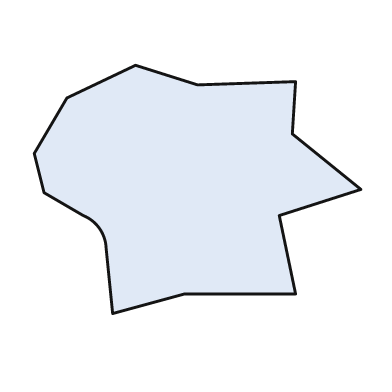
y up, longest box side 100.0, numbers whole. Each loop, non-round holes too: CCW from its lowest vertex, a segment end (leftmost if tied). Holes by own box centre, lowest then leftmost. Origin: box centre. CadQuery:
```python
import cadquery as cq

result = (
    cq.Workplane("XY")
    .moveTo(-26.0, -38.0)
    .lineTo(-4.0, -32.0)
    .lineTo(30.0, -32.0)
    .lineTo(25.0, -8.0)
    .lineTo(50.0, 0.0)
    .lineTo(29.0, 17.0)
    .lineTo(30.0, 33.0)
    .lineTo(0.0, 32.0)
    .lineTo(-19.0, 38.0)
    .lineTo(-40.0, 28.0)
    .lineTo(-50.0, 11.0)
    .lineTo(-47.0, -1.0)
    .lineTo(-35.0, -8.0)
    .threePointArc((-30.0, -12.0), (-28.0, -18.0))
    .close()
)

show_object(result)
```